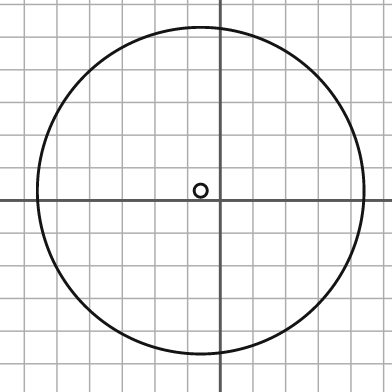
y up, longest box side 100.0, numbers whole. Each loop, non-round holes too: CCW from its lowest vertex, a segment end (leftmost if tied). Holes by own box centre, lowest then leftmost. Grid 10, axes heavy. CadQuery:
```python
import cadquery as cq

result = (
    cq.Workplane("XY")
    .moveTo(-6.0, 3.0)
    .circle(50.0)
    .moveTo(-6.0, 3.0)
    .circle(2.0)
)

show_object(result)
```